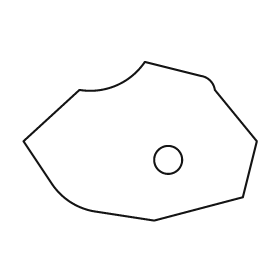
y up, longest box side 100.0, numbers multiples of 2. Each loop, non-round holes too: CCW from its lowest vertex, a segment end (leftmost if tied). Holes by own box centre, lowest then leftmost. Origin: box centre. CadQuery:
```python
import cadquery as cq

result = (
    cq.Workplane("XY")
    .moveTo(6.0, -34.0)
    .lineTo(44.0, -24.0)
    .lineTo(50.0, 0.0)
    .lineTo(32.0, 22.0)
    .threePointArc((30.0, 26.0), (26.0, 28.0))
    .lineTo(2.0, 34.0)
    .threePointArc((-10.0, 24.0), (-26.0, 22.0))
    .lineTo(-50.0, 0.0)
    .lineTo(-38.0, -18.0)
    .threePointArc((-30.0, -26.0), (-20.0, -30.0))
    .close()
    .moveTo(12.0, -8.0)
    .circle(6.0)
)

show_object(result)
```